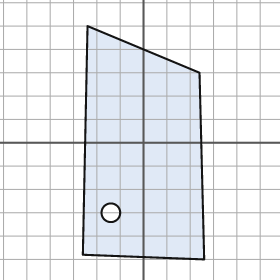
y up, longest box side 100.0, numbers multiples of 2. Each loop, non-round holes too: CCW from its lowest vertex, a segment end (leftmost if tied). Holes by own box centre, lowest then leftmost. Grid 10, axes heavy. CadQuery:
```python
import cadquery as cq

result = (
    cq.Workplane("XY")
    .moveTo(26.0, -50.0)
    .lineTo(24.0, 30.0)
    .lineTo(-24.0, 50.0)
    .lineTo(-26.0, -48.0)
    .close()
    .moveTo(-14.0, -30.0)
    .circle(4.0)
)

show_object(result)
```